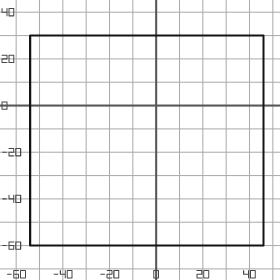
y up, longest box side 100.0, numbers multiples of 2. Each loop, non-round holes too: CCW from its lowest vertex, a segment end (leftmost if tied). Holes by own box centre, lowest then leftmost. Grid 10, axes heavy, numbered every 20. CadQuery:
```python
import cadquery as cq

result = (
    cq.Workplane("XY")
    .moveTo(-54.0, -60.0)
    .lineTo(46.0, -60.0)
    .lineTo(46.0, 30.0)
    .lineTo(-54.0, 30.0)
    .close()
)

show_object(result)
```